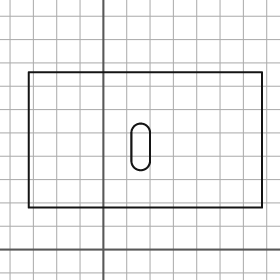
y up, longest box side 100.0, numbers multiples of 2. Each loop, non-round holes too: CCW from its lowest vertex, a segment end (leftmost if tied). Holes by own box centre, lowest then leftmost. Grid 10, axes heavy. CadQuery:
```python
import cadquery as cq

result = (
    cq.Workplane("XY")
    .moveTo(-32.0, 18.0)
    .lineTo(68.0, 18.0)
    .lineTo(68.0, 76.0)
    .lineTo(-32.0, 76.0)
    .close()
    .moveTo(12.0, 38.0)
    .threePointArc((16.0, 34.0), (20.0, 38.0))
    .lineTo(20.0, 50.0)
    .threePointArc((16.0, 54.0), (12.0, 50.0))
    .close()
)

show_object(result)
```